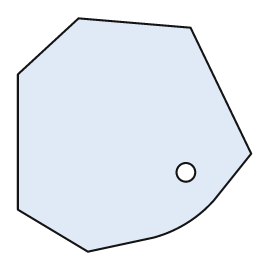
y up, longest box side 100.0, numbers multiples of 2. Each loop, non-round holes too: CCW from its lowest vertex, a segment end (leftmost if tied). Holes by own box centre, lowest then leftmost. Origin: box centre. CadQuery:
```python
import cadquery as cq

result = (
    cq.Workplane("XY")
    .moveTo(-20.0, -50.0)
    .lineTo(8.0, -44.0)
    .threePointArc((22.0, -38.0), (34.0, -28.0))
    .lineTo(50.0, -8.0)
    .lineTo(24.0, 46.0)
    .lineTo(-24.0, 50.0)
    .lineTo(-50.0, 26.0)
    .lineTo(-50.0, -32.0)
    .close()
    .moveTo(22.0, -16.0)
    .circle(4.0)
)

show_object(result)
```